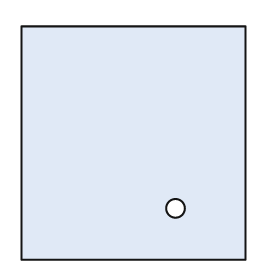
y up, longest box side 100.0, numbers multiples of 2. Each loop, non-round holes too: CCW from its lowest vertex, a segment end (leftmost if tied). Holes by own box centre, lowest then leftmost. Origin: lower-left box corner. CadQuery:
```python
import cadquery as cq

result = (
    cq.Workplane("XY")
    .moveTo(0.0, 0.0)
    .lineTo(96.0, 0.0)
    .lineTo(96.0, 100.0)
    .lineTo(0.0, 100.0)
    .close()
    .moveTo(66.0, 22.0)
    .circle(4.0)
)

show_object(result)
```